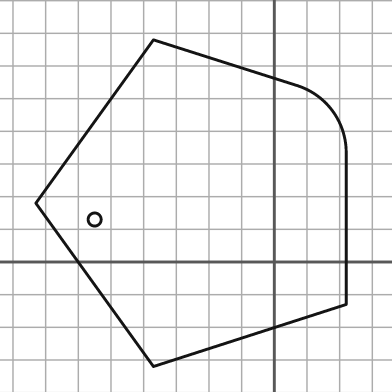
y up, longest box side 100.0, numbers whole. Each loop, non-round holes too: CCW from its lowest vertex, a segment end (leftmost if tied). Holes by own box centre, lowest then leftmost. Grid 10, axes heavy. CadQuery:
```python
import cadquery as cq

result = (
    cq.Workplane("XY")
    .moveTo(-37.0, -32.0)
    .lineTo(22.0, -13.0)
    .lineTo(22.0, 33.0)
    .threePointArc((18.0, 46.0), (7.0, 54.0))
    .lineTo(-37.0, 68.0)
    .lineTo(-73.0, 18.0)
    .close()
    .moveTo(-55.0, 13.0)
    .circle(2.0)
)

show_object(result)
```